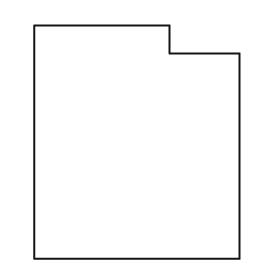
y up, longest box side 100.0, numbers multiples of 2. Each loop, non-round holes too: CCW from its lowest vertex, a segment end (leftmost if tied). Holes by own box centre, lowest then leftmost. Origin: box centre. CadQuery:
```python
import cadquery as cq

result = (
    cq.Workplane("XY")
    .moveTo(-44.0, -50.0)
    .lineTo(44.0, -50.0)
    .lineTo(44.0, 38.0)
    .lineTo(14.0, 38.0)
    .lineTo(14.0, 50.0)
    .lineTo(-44.0, 50.0)
    .close()
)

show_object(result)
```